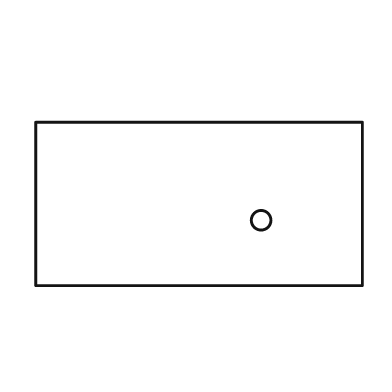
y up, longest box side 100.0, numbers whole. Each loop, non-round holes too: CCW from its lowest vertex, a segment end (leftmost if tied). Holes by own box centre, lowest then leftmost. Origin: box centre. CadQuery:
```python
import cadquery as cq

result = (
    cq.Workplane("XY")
    .moveTo(-50.0, -25.0)
    .lineTo(50.0, -25.0)
    .lineTo(50.0, 25.0)
    .lineTo(-50.0, 25.0)
    .close()
    .moveTo(19.0, -5.0)
    .circle(3.0)
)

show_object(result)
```